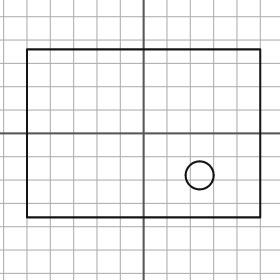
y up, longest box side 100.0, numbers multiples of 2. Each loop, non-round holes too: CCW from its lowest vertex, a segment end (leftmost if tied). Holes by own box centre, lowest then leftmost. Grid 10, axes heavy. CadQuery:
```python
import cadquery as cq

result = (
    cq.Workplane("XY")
    .moveTo(-50.0, -36.0)
    .lineTo(50.0, -36.0)
    .lineTo(50.0, 36.0)
    .lineTo(-50.0, 36.0)
    .close()
    .moveTo(24.0, -18.0)
    .circle(6.0)
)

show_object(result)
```